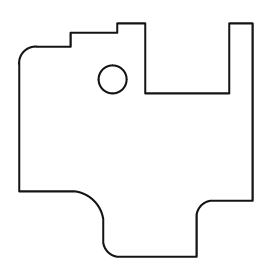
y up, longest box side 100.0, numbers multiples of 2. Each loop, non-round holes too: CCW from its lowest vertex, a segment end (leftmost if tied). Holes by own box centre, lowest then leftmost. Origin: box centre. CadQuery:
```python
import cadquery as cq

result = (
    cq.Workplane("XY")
    .moveTo(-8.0, -50.0)
    .lineTo(26.0, -50.0)
    .lineTo(26.0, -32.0)
    .threePointArc((28.0, -28.0), (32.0, -26.0))
    .lineTo(50.0, -26.0)
    .lineTo(50.0, 50.0)
    .lineTo(40.0, 50.0)
    .lineTo(40.0, 20.0)
    .lineTo(4.0, 20.0)
    .lineTo(4.0, 50.0)
    .lineTo(-8.0, 50.0)
    .lineTo(-8.0, 46.0)
    .lineTo(-28.0, 46.0)
    .lineTo(-28.0, 40.0)
    .lineTo(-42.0, 40.0)
    .threePointArc((-48.0, 38.0), (-50.0, 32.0))
    .lineTo(-50.0, -22.0)
    .lineTo(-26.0, -22.0)
    .threePointArc((-18.0, -26.0), (-14.0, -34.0))
    .lineTo(-14.0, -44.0)
    .threePointArc((-12.0, -48.0), (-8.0, -50.0))
    .close()
    .moveTo(-10.0, 26.0)
    .circle(6.0)
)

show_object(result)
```